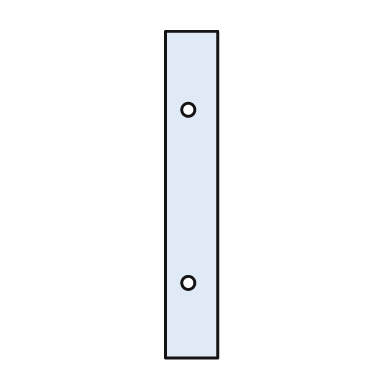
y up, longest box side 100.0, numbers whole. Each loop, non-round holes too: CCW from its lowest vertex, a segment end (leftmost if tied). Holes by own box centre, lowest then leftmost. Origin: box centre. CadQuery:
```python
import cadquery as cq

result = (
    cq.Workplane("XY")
    .moveTo(-8.0, -50.0)
    .lineTo(8.0, -50.0)
    .lineTo(8.0, 50.0)
    .lineTo(-8.0, 50.0)
    .close()
    .moveTo(-1.0, -27.0)
    .circle(2.0)
    .moveTo(-1.0, 26.0)
    .circle(2.0)
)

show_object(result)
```